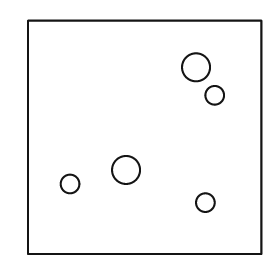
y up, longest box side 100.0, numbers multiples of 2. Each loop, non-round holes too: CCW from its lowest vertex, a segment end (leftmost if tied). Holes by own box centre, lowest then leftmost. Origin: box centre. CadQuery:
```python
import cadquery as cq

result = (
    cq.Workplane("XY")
    .moveTo(-50.0, -50.0)
    .lineTo(50.0, -50.0)
    .lineTo(50.0, 50.0)
    .lineTo(-50.0, 50.0)
    .close()
    .moveTo(26.0, -28.0)
    .circle(4.0)
    .moveTo(-32.0, -20.0)
    .circle(4.0)
    .moveTo(-8.0, -14.0)
    .circle(6.0)
    .moveTo(30.0, 18.0)
    .circle(4.0)
    .moveTo(22.0, 30.0)
    .circle(6.0)
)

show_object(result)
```